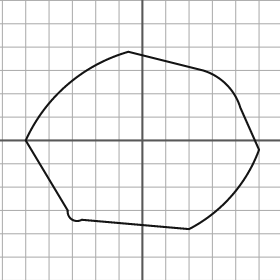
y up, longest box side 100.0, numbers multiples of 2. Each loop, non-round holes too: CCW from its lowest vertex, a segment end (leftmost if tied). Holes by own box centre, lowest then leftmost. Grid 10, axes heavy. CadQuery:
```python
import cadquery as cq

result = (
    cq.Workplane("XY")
    .moveTo(20.0, -38.0)
    .threePointArc((38.0, -24.0), (50.0, -4.0))
    .lineTo(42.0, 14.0)
    .threePointArc((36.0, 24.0), (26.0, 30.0))
    .lineTo(-6.0, 38.0)
    .threePointArc((-32.0, 24.0), (-50.0, 0.0))
    .lineTo(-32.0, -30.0)
    .threePointArc((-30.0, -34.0), (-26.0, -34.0))
    .close()
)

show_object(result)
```